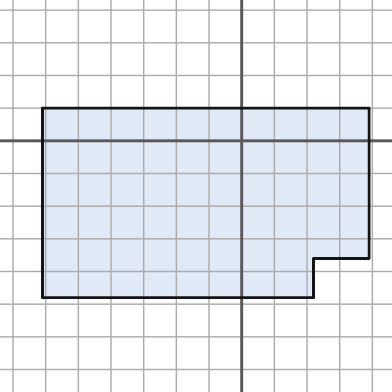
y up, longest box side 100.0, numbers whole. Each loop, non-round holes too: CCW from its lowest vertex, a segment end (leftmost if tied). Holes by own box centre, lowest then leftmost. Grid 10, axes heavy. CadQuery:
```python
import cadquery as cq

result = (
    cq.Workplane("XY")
    .moveTo(-61.0, -48.0)
    .lineTo(22.0, -48.0)
    .lineTo(22.0, -36.0)
    .lineTo(39.0, -36.0)
    .lineTo(39.0, 10.0)
    .lineTo(-61.0, 10.0)
    .close()
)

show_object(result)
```